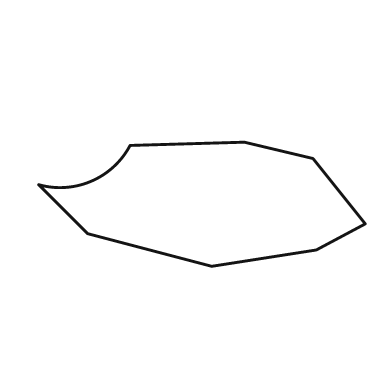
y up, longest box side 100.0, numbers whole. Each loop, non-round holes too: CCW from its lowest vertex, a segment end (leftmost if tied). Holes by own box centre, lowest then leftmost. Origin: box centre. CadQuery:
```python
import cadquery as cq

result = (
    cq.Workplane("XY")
    .moveTo(3.0, -19.0)
    .lineTo(35.0, -14.0)
    .lineTo(50.0, -6.0)
    .lineTo(34.0, 14.0)
    .lineTo(13.0, 19.0)
    .lineTo(-22.0, 18.0)
    .threePointArc((-34.0, 7.0), (-50.0, 6.0))
    .lineTo(-35.0, -9.0)
    .close()
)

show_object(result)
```